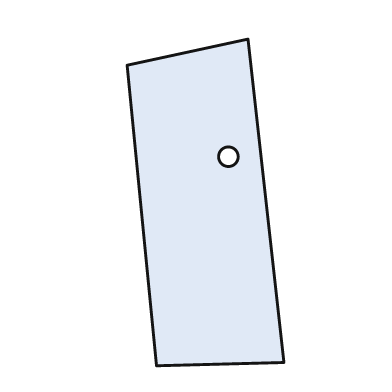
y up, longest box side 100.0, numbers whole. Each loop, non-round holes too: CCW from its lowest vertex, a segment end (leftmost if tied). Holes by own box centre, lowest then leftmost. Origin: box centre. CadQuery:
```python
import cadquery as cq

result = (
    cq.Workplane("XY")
    .moveTo(-15.0, -50.0)
    .lineTo(24.0, -49.0)
    .lineTo(13.0, 50.0)
    .lineTo(-24.0, 42.0)
    .close()
    .moveTo(7.0, 14.0)
    .circle(3.0)
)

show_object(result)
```